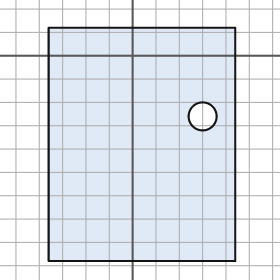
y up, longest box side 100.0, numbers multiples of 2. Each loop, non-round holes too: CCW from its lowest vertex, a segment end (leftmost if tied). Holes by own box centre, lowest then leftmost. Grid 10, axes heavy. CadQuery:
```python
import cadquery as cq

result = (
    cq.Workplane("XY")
    .moveTo(-36.0, -88.0)
    .lineTo(44.0, -88.0)
    .lineTo(44.0, 12.0)
    .lineTo(-36.0, 12.0)
    .close()
    .moveTo(30.0, -26.0)
    .circle(6.0)
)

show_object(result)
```